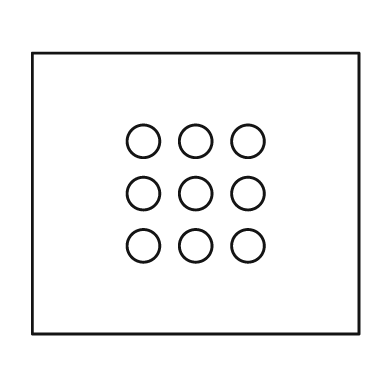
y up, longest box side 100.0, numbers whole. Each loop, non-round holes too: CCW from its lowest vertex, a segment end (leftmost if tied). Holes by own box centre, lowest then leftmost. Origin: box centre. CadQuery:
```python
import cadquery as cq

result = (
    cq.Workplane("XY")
    .moveTo(-50.0, -43.0)
    .lineTo(50.0, -43.0)
    .lineTo(50.0, 43.0)
    .lineTo(-50.0, 43.0)
    .close()
    .moveTo(-16.0, -16.0)
    .circle(5.0)
    .moveTo(0.0, -16.0)
    .circle(5.0)
    .moveTo(16.0, -16.0)
    .circle(5.0)
    .moveTo(-16.0, 0.0)
    .circle(5.0)
    .moveTo(0.0, 0.0)
    .circle(5.0)
    .moveTo(16.0, 0.0)
    .circle(5.0)
    .moveTo(-16.0, 16.0)
    .circle(5.0)
    .moveTo(0.0, 16.0)
    .circle(5.0)
    .moveTo(16.0, 16.0)
    .circle(5.0)
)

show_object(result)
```